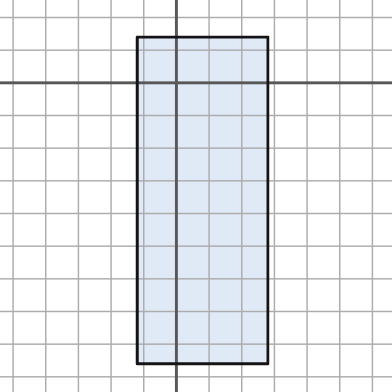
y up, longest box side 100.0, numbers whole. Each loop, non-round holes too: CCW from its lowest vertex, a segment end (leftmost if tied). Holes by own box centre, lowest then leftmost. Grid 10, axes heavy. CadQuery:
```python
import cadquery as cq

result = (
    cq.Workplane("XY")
    .moveTo(-12.0, -86.0)
    .lineTo(28.0, -86.0)
    .lineTo(28.0, 14.0)
    .lineTo(-12.0, 14.0)
    .close()
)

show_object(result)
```